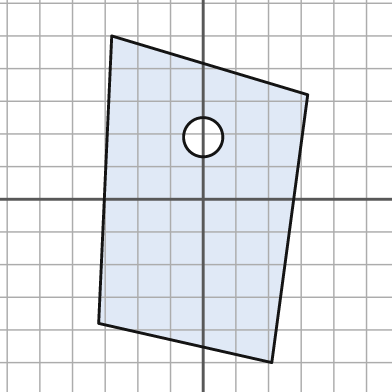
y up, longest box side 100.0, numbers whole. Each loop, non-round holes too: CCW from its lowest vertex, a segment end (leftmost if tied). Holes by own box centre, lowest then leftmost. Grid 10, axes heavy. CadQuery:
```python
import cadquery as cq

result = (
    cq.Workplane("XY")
    .moveTo(21.0, -50.0)
    .lineTo(32.0, 32.0)
    .lineTo(-28.0, 50.0)
    .lineTo(-32.0, -38.0)
    .close()
    .moveTo(0.0, 19.0)
    .circle(6.0)
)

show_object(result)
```